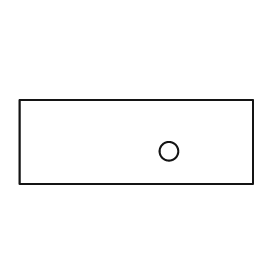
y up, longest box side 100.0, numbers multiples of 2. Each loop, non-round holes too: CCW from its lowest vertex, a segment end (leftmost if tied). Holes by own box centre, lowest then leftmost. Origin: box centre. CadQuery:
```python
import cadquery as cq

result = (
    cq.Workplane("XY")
    .moveTo(-50.0, -18.0)
    .lineTo(50.0, -18.0)
    .lineTo(50.0, 18.0)
    .lineTo(-50.0, 18.0)
    .close()
    .moveTo(14.0, -4.0)
    .circle(4.0)
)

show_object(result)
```